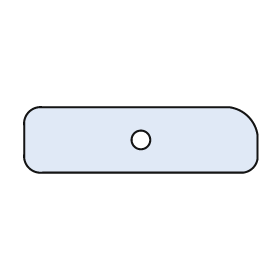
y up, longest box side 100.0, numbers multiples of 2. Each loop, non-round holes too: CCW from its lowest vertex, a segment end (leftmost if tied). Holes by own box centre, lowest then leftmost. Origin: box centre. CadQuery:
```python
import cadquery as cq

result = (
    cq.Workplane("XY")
    .moveTo(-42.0, -14.0)
    .lineTo(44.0, -14.0)
    .threePointArc((48.0, -12.0), (50.0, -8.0))
    .lineTo(50.0, 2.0)
    .threePointArc((46.0, 10.0), (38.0, 14.0))
    .lineTo(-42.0, 14.0)
    .threePointArc((-48.0, 12.0), (-50.0, 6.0))
    .lineTo(-50.0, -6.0)
    .threePointArc((-48.0, -12.0), (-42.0, -14.0))
    .close()
    .moveTo(0.0, 0.0)
    .circle(4.0)
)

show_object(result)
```